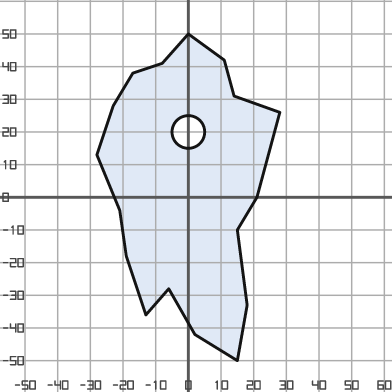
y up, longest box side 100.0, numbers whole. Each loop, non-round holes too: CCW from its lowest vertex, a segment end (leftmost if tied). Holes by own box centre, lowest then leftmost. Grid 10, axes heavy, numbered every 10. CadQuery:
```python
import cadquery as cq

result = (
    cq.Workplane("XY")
    .moveTo(15.0, -50.0)
    .lineTo(18.0, -33.0)
    .lineTo(15.0, -10.0)
    .lineTo(21.0, 0.0)
    .lineTo(28.0, 26.0)
    .lineTo(14.0, 31.0)
    .lineTo(11.0, 42.0)
    .lineTo(0.0, 50.0)
    .lineTo(-8.0, 41.0)
    .lineTo(-17.0, 38.0)
    .lineTo(-23.0, 28.0)
    .lineTo(-28.0, 13.0)
    .lineTo(-21.0, -4.0)
    .lineTo(-19.0, -18.0)
    .lineTo(-13.0, -36.0)
    .lineTo(-6.0, -28.0)
    .lineTo(2.0, -42.0)
    .close()
    .moveTo(0.0, 20.0)
    .circle(5.0)
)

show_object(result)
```